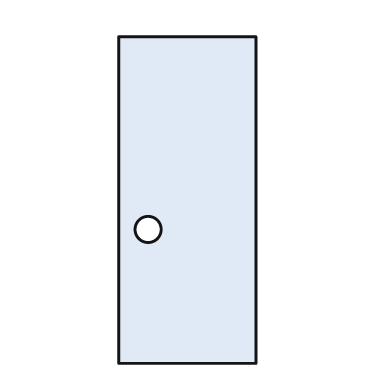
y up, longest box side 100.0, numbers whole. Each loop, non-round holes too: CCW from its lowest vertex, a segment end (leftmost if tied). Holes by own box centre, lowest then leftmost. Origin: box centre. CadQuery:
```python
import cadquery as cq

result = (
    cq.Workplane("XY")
    .moveTo(-21.0, -50.0)
    .lineTo(21.0, -50.0)
    .lineTo(21.0, 50.0)
    .lineTo(-21.0, 50.0)
    .close()
    .moveTo(-12.0, -9.0)
    .circle(4.0)
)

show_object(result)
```